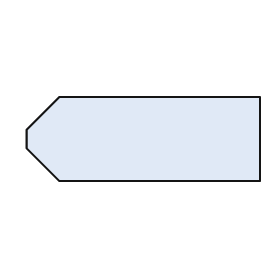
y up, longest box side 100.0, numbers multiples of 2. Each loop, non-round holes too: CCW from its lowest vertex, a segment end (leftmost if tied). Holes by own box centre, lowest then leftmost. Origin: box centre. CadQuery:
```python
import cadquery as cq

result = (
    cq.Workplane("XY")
    .moveTo(-36.0, -18.0)
    .lineTo(50.0, -18.0)
    .lineTo(50.0, 18.0)
    .lineTo(-36.0, 18.0)
    .lineTo(-50.0, 4.0)
    .lineTo(-50.0, -4.0)
    .close()
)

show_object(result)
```